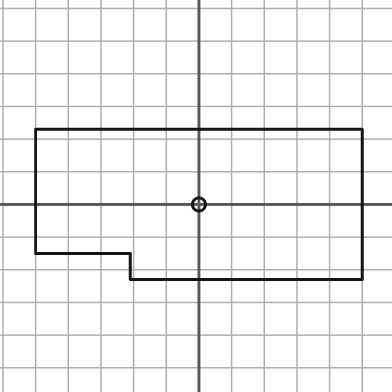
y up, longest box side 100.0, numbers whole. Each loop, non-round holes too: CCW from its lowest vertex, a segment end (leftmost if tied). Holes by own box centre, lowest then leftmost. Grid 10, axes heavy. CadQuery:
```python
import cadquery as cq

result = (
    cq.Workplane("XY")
    .moveTo(-21.0, -23.0)
    .lineTo(50.0, -23.0)
    .lineTo(50.0, 23.0)
    .lineTo(-50.0, 23.0)
    .lineTo(-50.0, -15.0)
    .lineTo(-21.0, -15.0)
    .close()
    .moveTo(0.0, 0.0)
    .circle(2.0)
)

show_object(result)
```